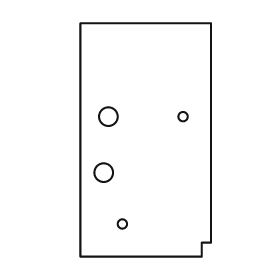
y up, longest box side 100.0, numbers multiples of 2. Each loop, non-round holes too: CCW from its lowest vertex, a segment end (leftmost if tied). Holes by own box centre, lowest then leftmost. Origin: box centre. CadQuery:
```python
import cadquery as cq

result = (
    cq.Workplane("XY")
    .moveTo(-28.0, -50.0)
    .lineTo(24.0, -50.0)
    .lineTo(24.0, -44.0)
    .lineTo(28.0, -44.0)
    .lineTo(28.0, 50.0)
    .lineTo(-28.0, 50.0)
    .close()
    .moveTo(-10.0, -36.0)
    .circle(2.0)
    .moveTo(-18.0, -14.0)
    .circle(4.0)
    .moveTo(-16.0, 10.0)
    .circle(4.0)
    .moveTo(16.0, 10.0)
    .circle(2.0)
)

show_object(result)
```